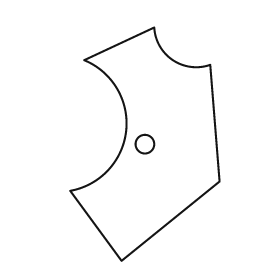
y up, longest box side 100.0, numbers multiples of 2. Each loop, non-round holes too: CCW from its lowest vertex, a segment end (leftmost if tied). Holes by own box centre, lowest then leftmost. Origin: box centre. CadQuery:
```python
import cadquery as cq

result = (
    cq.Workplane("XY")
    .moveTo(-10.0, -50.0)
    .lineTo(32.0, -16.0)
    .lineTo(28.0, 34.0)
    .threePointArc((12.0, 36.0), (4.0, 50.0))
    .lineTo(-26.0, 36.0)
    .threePointArc((-8.0, 6.0), (-32.0, -20.0))
    .close()
    .moveTo(0.0, 0.0)
    .circle(4.0)
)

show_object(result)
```